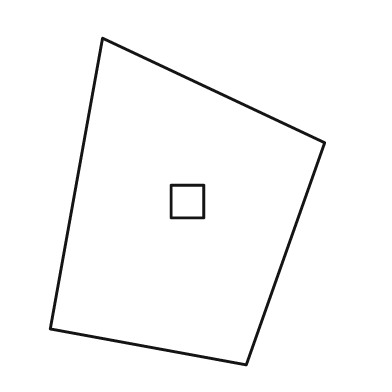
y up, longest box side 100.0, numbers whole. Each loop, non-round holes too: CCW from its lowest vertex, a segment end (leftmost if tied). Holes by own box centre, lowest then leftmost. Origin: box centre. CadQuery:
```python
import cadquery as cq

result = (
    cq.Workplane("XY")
    .moveTo(18.0, -50.0)
    .lineTo(42.0, 18.0)
    .lineTo(-26.0, 50.0)
    .lineTo(-42.0, -39.0)
    .close()
    .moveTo(-5.0, -5.0)
    .lineTo(5.0, -5.0)
    .lineTo(5.0, 5.0)
    .lineTo(-5.0, 5.0)
    .close()
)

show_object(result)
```